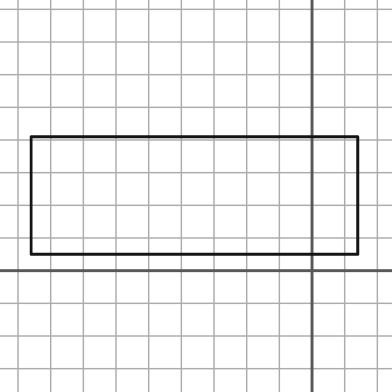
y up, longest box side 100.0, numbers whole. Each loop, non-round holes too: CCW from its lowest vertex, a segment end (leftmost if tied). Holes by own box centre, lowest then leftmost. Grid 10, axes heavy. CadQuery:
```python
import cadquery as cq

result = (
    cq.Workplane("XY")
    .moveTo(-86.0, 5.0)
    .lineTo(14.0, 5.0)
    .lineTo(14.0, 41.0)
    .lineTo(-86.0, 41.0)
    .close()
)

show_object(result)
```